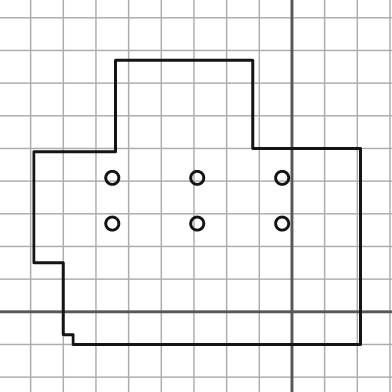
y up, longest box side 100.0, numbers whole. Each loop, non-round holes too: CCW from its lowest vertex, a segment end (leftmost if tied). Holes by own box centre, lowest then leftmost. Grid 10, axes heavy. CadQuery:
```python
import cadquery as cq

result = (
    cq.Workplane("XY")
    .moveTo(-67.0, -10.0)
    .lineTo(21.0, -10.0)
    .lineTo(21.0, 50.0)
    .lineTo(-12.0, 50.0)
    .lineTo(-12.0, 77.0)
    .lineTo(-54.0, 77.0)
    .lineTo(-54.0, 49.0)
    .lineTo(-79.0, 49.0)
    .lineTo(-79.0, 15.0)
    .lineTo(-70.0, 15.0)
    .lineTo(-70.0, -7.0)
    .lineTo(-67.0, -7.0)
    .close()
    .moveTo(-55.0, 27.0)
    .circle(2.0)
    .moveTo(-29.0, 27.0)
    .circle(2.0)
    .moveTo(-3.0, 27.0)
    .circle(2.0)
    .moveTo(-55.0, 41.0)
    .circle(2.0)
    .moveTo(-29.0, 41.0)
    .circle(2.0)
    .moveTo(-3.0, 41.0)
    .circle(2.0)
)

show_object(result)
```